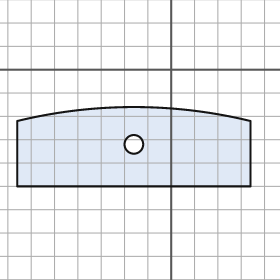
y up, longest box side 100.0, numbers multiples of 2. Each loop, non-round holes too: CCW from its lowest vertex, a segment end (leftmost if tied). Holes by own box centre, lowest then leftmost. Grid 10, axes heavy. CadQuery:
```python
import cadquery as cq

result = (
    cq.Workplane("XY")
    .moveTo(-66.0, -50.0)
    .lineTo(34.0, -50.0)
    .lineTo(34.0, -22.0)
    .threePointArc((-16.0, -16.0), (-66.0, -22.0))
    .close()
    .moveTo(-16.0, -32.0)
    .circle(4.0)
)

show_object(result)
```